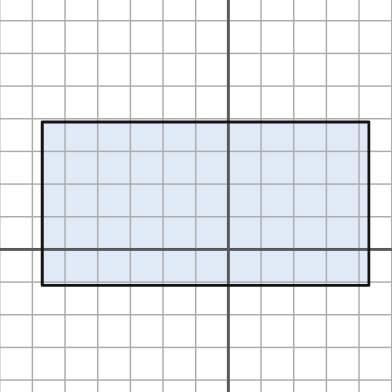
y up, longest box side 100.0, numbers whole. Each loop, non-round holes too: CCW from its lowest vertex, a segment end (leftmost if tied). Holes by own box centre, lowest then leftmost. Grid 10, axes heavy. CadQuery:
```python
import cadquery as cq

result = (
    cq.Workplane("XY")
    .moveTo(-57.0, -11.0)
    .lineTo(43.0, -11.0)
    .lineTo(43.0, 39.0)
    .lineTo(-57.0, 39.0)
    .close()
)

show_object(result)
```